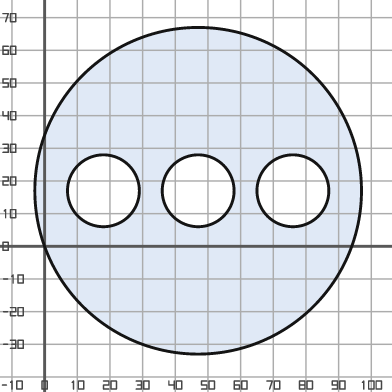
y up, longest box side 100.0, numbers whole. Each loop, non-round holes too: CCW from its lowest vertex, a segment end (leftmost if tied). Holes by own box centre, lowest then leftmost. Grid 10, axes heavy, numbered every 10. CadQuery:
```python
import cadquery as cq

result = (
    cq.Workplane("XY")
    .moveTo(47.0, 17.0)
    .circle(50.0)
    .moveTo(18.0, 17.0)
    .circle(11.0)
    .moveTo(47.0, 17.0)
    .circle(11.0)
    .moveTo(76.0, 17.0)
    .circle(11.0)
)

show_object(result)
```